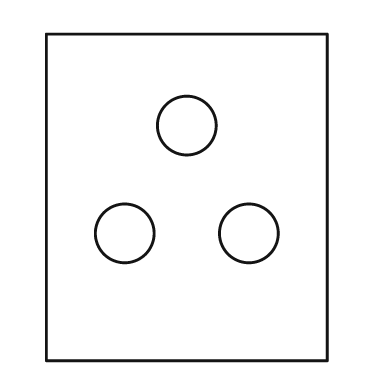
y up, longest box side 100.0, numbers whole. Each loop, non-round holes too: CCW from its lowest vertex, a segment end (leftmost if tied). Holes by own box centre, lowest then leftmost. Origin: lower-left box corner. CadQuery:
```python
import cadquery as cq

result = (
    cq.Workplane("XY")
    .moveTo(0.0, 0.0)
    .lineTo(86.0, 0.0)
    .lineTo(86.0, 100.0)
    .lineTo(0.0, 100.0)
    .close()
    .moveTo(24.0, 39.0)
    .circle(9.0)
    .moveTo(62.0, 39.0)
    .circle(9.0)
    .moveTo(43.0, 72.0)
    .circle(9.0)
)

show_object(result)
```